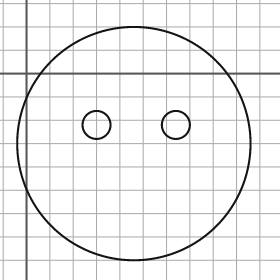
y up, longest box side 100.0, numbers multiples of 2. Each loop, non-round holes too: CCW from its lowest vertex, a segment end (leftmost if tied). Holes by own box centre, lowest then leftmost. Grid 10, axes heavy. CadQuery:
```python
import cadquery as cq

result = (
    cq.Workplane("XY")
    .moveTo(46.0, -30.0)
    .circle(50.0)
    .moveTo(30.0, -22.0)
    .circle(6.0)
    .moveTo(64.0, -22.0)
    .circle(6.0)
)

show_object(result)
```